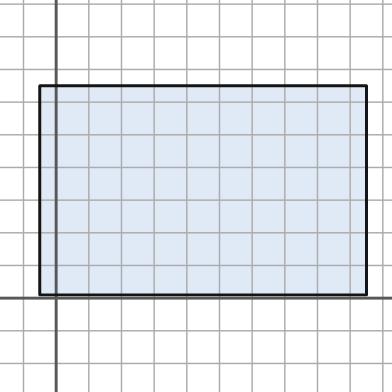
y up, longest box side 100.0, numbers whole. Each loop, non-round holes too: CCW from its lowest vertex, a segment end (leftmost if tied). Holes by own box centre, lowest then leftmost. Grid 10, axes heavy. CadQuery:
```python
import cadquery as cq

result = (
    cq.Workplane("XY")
    .moveTo(-5.0, 1.0)
    .lineTo(95.0, 1.0)
    .lineTo(95.0, 65.0)
    .lineTo(-5.0, 65.0)
    .close()
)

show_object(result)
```